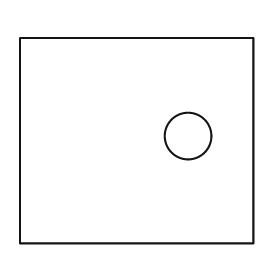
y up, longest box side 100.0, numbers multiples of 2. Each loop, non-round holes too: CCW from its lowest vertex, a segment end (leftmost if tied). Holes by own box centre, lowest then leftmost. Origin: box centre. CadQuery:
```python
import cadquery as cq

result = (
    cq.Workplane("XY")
    .moveTo(-50.0, -44.0)
    .lineTo(50.0, -44.0)
    .lineTo(50.0, 44.0)
    .lineTo(-50.0, 44.0)
    .close()
    .moveTo(22.0, 2.0)
    .circle(10.0)
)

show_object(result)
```